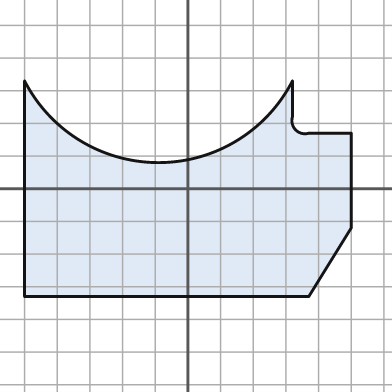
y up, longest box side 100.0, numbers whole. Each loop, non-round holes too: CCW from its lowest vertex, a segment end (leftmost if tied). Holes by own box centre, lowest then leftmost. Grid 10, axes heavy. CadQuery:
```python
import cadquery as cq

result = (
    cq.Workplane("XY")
    .moveTo(-50.0, -33.0)
    .lineTo(37.0, -33.0)
    .lineTo(50.0, -12.0)
    .lineTo(50.0, 17.0)
    .lineTo(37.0, 17.0)
    .threePointArc((33.0, 18.0), (32.0, 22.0))
    .lineTo(32.0, 33.0)
    .threePointArc((-9.0, 8.0), (-50.0, 33.0))
    .close()
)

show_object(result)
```